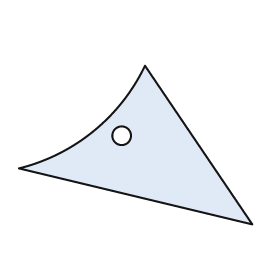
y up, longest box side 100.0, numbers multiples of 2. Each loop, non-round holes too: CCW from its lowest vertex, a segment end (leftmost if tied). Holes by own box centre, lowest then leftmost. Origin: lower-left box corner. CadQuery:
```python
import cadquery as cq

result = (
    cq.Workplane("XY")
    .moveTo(100.0, 0.0)
    .lineTo(54.0, 68.0)
    .threePointArc((32.0, 40.0), (0.0, 24.0))
    .close()
    .moveTo(44.0, 38.0)
    .circle(4.0)
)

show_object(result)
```